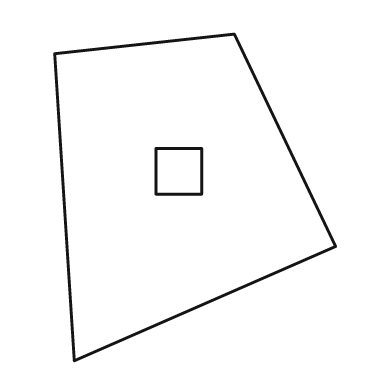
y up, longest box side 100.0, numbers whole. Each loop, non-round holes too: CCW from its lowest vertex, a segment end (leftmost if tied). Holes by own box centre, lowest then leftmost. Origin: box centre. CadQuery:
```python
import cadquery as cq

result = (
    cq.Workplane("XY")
    .moveTo(-37.0, -50.0)
    .lineTo(43.0, -15.0)
    .lineTo(12.0, 50.0)
    .lineTo(-43.0, 44.0)
    .close()
    .moveTo(-12.0, 1.0)
    .lineTo(2.0, 1.0)
    .lineTo(2.0, 15.0)
    .lineTo(-12.0, 15.0)
    .close()
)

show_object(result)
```